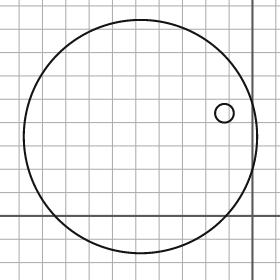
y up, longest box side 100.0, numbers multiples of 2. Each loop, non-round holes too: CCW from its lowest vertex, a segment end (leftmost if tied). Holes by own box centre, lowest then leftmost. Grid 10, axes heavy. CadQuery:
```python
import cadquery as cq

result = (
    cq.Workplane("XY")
    .moveTo(-48.0, 34.0)
    .circle(50.0)
    .moveTo(-12.0, 44.0)
    .circle(4.0)
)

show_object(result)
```